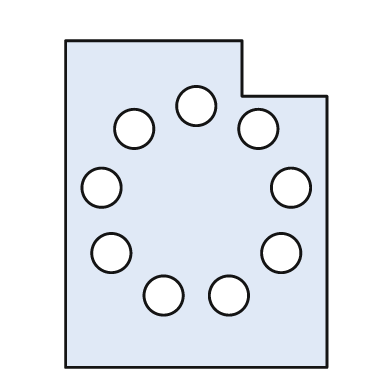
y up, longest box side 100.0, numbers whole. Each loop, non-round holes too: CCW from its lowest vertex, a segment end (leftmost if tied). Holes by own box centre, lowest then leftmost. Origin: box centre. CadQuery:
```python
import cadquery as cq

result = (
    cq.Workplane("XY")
    .moveTo(-40.0, -50.0)
    .lineTo(40.0, -50.0)
    .lineTo(40.0, 33.0)
    .lineTo(14.0, 33.0)
    .lineTo(14.0, 50.0)
    .lineTo(-40.0, 50.0)
    .close()
    .moveTo(-10.0, -28.0)
    .circle(6.0)
    .moveTo(10.0, -28.0)
    .circle(6.0)
    .moveTo(-26.0, -15.0)
    .circle(6.0)
    .moveTo(26.0, -15.0)
    .circle(6.0)
    .moveTo(-29.0, 5.0)
    .circle(6.0)
    .moveTo(29.0, 5.0)
    .circle(6.0)
    .moveTo(-19.0, 23.0)
    .circle(6.0)
    .moveTo(19.0, 23.0)
    .circle(6.0)
    .moveTo(0.0, 30.0)
    .circle(6.0)
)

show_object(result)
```